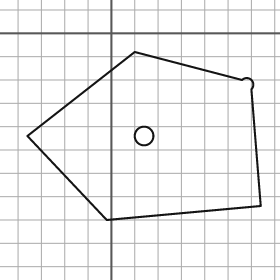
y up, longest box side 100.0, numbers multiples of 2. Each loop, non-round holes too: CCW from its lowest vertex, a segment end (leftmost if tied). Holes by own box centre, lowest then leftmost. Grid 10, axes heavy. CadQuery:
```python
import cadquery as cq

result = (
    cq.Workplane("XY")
    .moveTo(-2.0, -80.0)
    .lineTo(64.0, -74.0)
    .lineTo(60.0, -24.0)
    .threePointArc((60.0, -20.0), (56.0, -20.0))
    .lineTo(10.0, -8.0)
    .lineTo(-36.0, -44.0)
    .close()
    .moveTo(14.0, -44.0)
    .circle(4.0)
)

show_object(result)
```